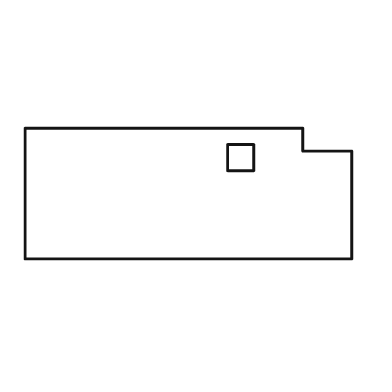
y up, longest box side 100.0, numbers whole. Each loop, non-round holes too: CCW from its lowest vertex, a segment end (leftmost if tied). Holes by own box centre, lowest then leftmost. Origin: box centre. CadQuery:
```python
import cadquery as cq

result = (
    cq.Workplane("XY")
    .moveTo(-50.0, -20.0)
    .lineTo(50.0, -20.0)
    .lineTo(50.0, 13.0)
    .lineTo(35.0, 13.0)
    .lineTo(35.0, 20.0)
    .lineTo(-50.0, 20.0)
    .close()
    .moveTo(12.0, 7.0)
    .lineTo(20.0, 7.0)
    .lineTo(20.0, 15.0)
    .lineTo(12.0, 15.0)
    .close()
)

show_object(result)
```